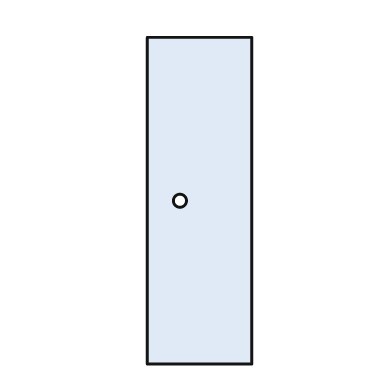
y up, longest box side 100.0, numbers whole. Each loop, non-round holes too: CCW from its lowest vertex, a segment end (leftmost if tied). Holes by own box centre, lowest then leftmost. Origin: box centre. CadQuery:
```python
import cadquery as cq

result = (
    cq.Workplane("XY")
    .moveTo(-16.0, -50.0)
    .lineTo(16.0, -50.0)
    .lineTo(16.0, 50.0)
    .lineTo(-16.0, 50.0)
    .close()
    .moveTo(-6.0, 0.0)
    .circle(2.0)
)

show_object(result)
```